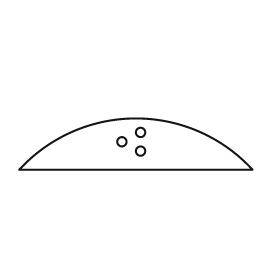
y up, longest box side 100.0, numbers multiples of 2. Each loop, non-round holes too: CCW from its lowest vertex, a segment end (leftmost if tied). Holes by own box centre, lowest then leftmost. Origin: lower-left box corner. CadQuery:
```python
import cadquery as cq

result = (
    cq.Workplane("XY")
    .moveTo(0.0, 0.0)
    .lineTo(100.0, 0.0)
    .threePointArc((50.0, 22.0), (0.0, 0.0))
    .close()
    .moveTo(52.0, 8.0)
    .circle(2.0)
    .moveTo(44.0, 12.0)
    .circle(2.0)
    .moveTo(52.0, 16.0)
    .circle(2.0)
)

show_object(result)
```